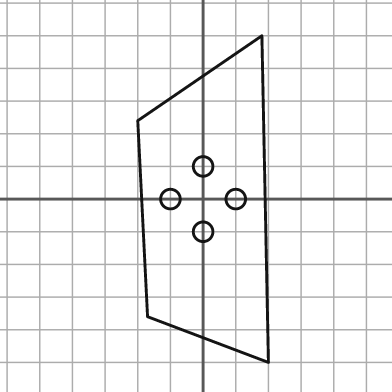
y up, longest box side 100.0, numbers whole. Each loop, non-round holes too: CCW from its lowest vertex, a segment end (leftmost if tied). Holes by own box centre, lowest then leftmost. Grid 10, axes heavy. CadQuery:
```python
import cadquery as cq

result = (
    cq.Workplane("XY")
    .moveTo(20.0, -50.0)
    .lineTo(18.0, 50.0)
    .lineTo(-20.0, 24.0)
    .lineTo(-17.0, -36.0)
    .close()
    .moveTo(0.0, -10.0)
    .circle(3.0)
    .moveTo(-10.0, 0.0)
    .circle(3.0)
    .moveTo(10.0, 0.0)
    .circle(3.0)
    .moveTo(0.0, 10.0)
    .circle(3.0)
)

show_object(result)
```